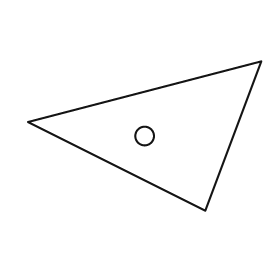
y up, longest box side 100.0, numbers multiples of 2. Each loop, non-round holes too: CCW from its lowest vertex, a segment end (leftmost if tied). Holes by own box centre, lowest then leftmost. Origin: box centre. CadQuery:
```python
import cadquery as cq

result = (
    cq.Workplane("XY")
    .moveTo(26.0, -32.0)
    .lineTo(50.0, 32.0)
    .lineTo(-50.0, 6.0)
    .close()
    .moveTo(0.0, 0.0)
    .circle(4.0)
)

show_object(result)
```